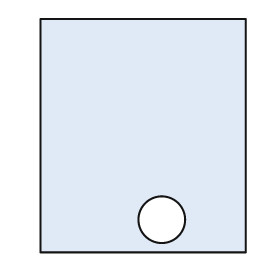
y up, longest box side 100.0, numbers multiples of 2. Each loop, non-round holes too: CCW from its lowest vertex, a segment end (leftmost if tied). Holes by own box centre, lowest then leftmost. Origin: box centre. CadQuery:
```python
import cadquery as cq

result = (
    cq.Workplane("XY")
    .moveTo(-44.0, -50.0)
    .lineTo(44.0, -50.0)
    .lineTo(44.0, 50.0)
    .lineTo(-44.0, 50.0)
    .close()
    .moveTo(8.0, -36.0)
    .circle(10.0)
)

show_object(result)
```